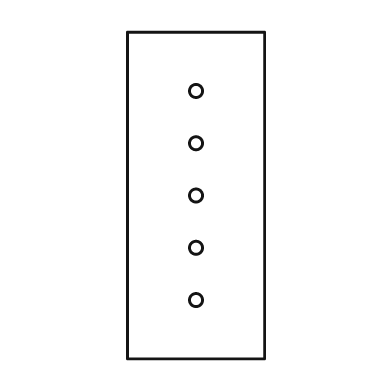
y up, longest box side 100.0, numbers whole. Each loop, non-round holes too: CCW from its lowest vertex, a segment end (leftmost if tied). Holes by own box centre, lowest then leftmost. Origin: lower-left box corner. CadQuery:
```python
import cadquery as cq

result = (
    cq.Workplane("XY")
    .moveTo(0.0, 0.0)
    .lineTo(42.0, 0.0)
    .lineTo(42.0, 100.0)
    .lineTo(0.0, 100.0)
    .close()
    .moveTo(21.0, 18.0)
    .circle(2.0)
    .moveTo(21.0, 34.0)
    .circle(2.0)
    .moveTo(21.0, 50.0)
    .circle(2.0)
    .moveTo(21.0, 66.0)
    .circle(2.0)
    .moveTo(21.0, 82.0)
    .circle(2.0)
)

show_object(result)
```